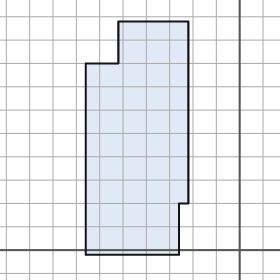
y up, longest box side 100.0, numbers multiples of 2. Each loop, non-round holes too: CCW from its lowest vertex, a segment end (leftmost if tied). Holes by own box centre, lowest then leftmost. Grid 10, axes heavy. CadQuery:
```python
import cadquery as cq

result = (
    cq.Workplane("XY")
    .moveTo(-66.0, -2.0)
    .lineTo(-26.0, -2.0)
    .lineTo(-26.0, 20.0)
    .lineTo(-22.0, 20.0)
    .lineTo(-22.0, 98.0)
    .lineTo(-52.0, 98.0)
    .lineTo(-52.0, 80.0)
    .lineTo(-66.0, 80.0)
    .close()
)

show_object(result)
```